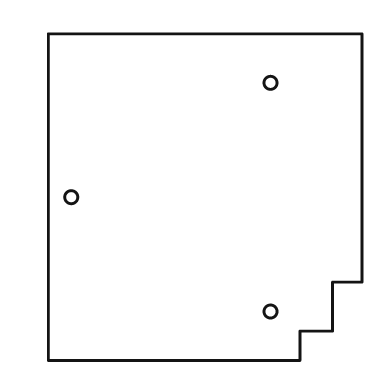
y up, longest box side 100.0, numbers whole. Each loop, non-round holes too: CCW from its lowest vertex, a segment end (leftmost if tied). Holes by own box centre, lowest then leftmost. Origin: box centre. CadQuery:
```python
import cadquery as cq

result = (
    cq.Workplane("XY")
    .moveTo(-48.0, -50.0)
    .lineTo(29.0, -50.0)
    .lineTo(29.0, -41.0)
    .lineTo(39.0, -41.0)
    .lineTo(39.0, -26.0)
    .lineTo(48.0, -26.0)
    .lineTo(48.0, 50.0)
    .lineTo(-48.0, 50.0)
    .close()
    .moveTo(20.0, -35.0)
    .circle(2.0)
    .moveTo(-41.0, 0.0)
    .circle(2.0)
    .moveTo(20.0, 35.0)
    .circle(2.0)
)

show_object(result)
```